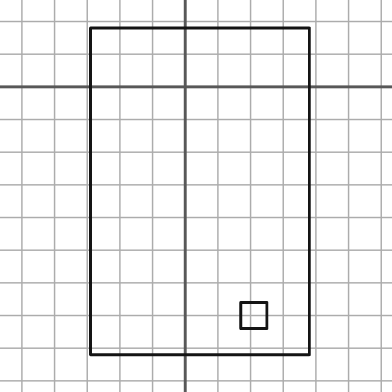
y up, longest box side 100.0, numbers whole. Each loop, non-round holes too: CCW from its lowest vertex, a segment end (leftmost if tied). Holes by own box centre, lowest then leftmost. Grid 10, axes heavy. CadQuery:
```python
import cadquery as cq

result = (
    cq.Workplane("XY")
    .moveTo(-29.0, -82.0)
    .lineTo(38.0, -82.0)
    .lineTo(38.0, 18.0)
    .lineTo(-29.0, 18.0)
    .close()
    .moveTo(17.0, -74.0)
    .lineTo(25.0, -74.0)
    .lineTo(25.0, -66.0)
    .lineTo(17.0, -66.0)
    .close()
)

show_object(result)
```